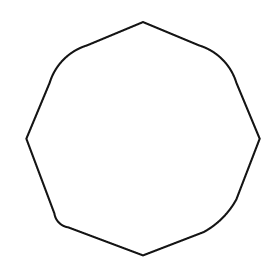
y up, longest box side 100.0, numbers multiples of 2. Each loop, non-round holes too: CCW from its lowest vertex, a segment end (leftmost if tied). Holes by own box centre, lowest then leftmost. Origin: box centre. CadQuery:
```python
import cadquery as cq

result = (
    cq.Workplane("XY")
    .moveTo(0.0, -50.0)
    .lineTo(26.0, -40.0)
    .threePointArc((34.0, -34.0), (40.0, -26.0))
    .lineTo(50.0, 0.0)
    .lineTo(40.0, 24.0)
    .threePointArc((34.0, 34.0), (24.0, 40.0))
    .lineTo(0.0, 50.0)
    .lineTo(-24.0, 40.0)
    .threePointArc((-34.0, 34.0), (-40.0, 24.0))
    .lineTo(-50.0, 0.0)
    .lineTo(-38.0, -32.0)
    .threePointArc((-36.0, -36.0), (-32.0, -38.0))
    .close()
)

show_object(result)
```